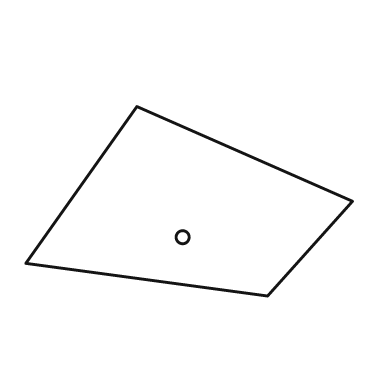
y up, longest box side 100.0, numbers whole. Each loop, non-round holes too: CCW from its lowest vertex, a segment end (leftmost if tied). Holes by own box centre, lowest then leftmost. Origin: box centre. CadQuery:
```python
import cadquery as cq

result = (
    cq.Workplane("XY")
    .moveTo(24.0, -29.0)
    .lineTo(50.0, 0.0)
    .lineTo(-16.0, 29.0)
    .lineTo(-50.0, -19.0)
    .close()
    .moveTo(-2.0, -11.0)
    .circle(2.0)
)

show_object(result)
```